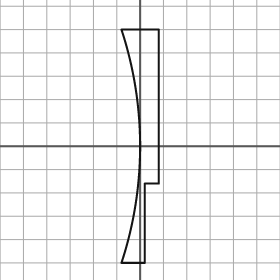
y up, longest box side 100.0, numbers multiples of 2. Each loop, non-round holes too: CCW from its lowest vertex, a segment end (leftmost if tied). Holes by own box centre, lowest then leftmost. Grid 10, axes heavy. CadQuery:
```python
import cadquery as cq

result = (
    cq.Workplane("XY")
    .moveTo(-8.0, -50.0)
    .lineTo(2.0, -50.0)
    .lineTo(2.0, -16.0)
    .lineTo(8.0, -16.0)
    .lineTo(8.0, 50.0)
    .lineTo(-8.0, 50.0)
    .threePointArc((0.0, 0.0), (-8.0, -50.0))
    .close()
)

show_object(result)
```